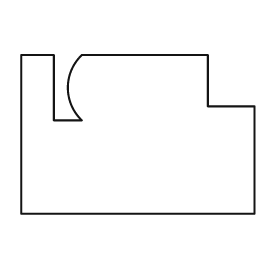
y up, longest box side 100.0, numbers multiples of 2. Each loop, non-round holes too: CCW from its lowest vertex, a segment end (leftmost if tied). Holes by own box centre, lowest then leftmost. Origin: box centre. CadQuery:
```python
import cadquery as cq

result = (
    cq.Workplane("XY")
    .moveTo(-50.0, -34.0)
    .lineTo(50.0, -34.0)
    .lineTo(50.0, 12.0)
    .lineTo(30.0, 12.0)
    .lineTo(30.0, 34.0)
    .lineTo(-24.0, 34.0)
    .threePointArc((-30.0, 20.0), (-24.0, 6.0))
    .lineTo(-36.0, 6.0)
    .lineTo(-36.0, 34.0)
    .lineTo(-50.0, 34.0)
    .close()
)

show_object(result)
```